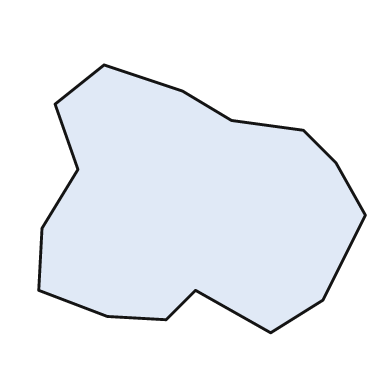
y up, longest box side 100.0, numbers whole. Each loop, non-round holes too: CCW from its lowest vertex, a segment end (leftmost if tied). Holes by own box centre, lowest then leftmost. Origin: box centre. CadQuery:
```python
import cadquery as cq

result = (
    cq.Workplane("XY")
    .moveTo(21.0, -41.0)
    .lineTo(37.0, -31.0)
    .lineTo(50.0, -5.0)
    .lineTo(41.0, 11.0)
    .lineTo(31.0, 21.0)
    .lineTo(9.0, 24.0)
    .lineTo(-6.0, 33.0)
    .lineTo(-30.0, 41.0)
    .lineTo(-45.0, 29.0)
    .lineTo(-38.0, 9.0)
    .lineTo(-49.0, -9.0)
    .lineTo(-50.0, -28.0)
    .lineTo(-29.0, -36.0)
    .lineTo(-11.0, -37.0)
    .lineTo(-2.0, -28.0)
    .close()
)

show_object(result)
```